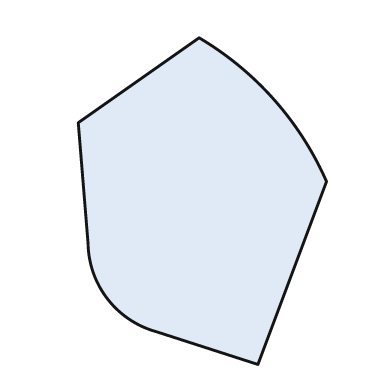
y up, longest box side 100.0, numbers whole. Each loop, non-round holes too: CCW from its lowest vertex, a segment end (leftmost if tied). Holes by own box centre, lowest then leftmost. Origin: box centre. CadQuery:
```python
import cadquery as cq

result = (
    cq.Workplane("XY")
    .moveTo(17.0, -50.0)
    .lineTo(38.0, 6.0)
    .threePointArc((22.0, 31.0), (-1.0, 50.0))
    .lineTo(-38.0, 24.0)
    .lineTo(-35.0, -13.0)
    .threePointArc((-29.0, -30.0), (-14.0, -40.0))
    .close()
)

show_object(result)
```